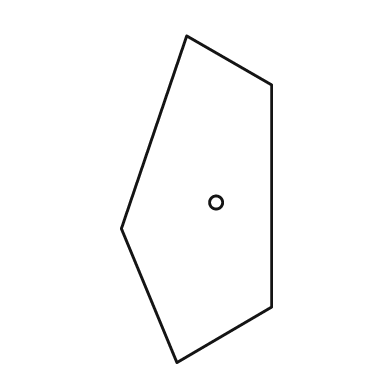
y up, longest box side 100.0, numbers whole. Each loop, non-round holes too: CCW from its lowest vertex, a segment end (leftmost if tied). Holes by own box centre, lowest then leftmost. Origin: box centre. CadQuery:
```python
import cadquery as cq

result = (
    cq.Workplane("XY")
    .moveTo(-6.0, -50.0)
    .lineTo(23.0, -33.0)
    .lineTo(23.0, 35.0)
    .lineTo(-3.0, 50.0)
    .lineTo(-23.0, -9.0)
    .close()
    .moveTo(6.0, -1.0)
    .circle(2.0)
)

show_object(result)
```